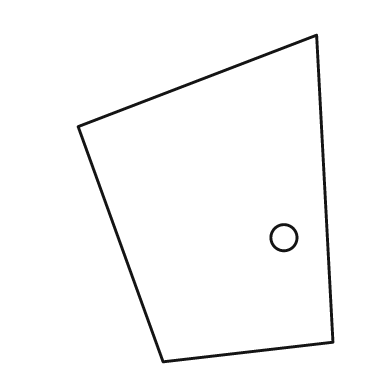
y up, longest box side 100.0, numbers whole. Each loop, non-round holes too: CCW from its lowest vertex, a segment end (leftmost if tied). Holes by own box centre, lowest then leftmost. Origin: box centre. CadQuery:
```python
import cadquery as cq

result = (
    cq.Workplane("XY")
    .moveTo(-13.0, -50.0)
    .lineTo(39.0, -44.0)
    .lineTo(34.0, 50.0)
    .lineTo(-39.0, 22.0)
    .close()
    .moveTo(24.0, -12.0)
    .circle(4.0)
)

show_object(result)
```